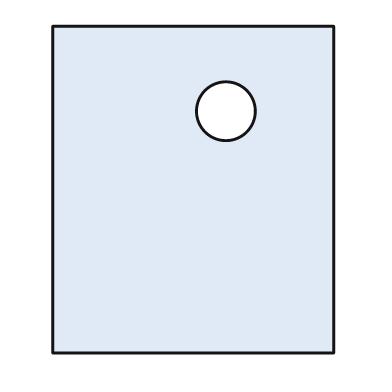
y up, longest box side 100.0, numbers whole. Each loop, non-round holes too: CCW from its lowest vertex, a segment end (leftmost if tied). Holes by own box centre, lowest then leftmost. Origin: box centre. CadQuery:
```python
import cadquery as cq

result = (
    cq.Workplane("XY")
    .moveTo(-43.0, -50.0)
    .lineTo(43.0, -50.0)
    .lineTo(43.0, 50.0)
    .lineTo(-43.0, 50.0)
    .close()
    .moveTo(10.0, 24.0)
    .circle(9.0)
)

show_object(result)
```